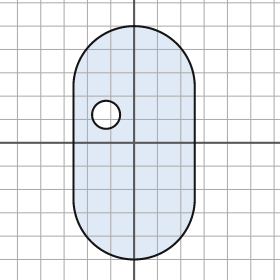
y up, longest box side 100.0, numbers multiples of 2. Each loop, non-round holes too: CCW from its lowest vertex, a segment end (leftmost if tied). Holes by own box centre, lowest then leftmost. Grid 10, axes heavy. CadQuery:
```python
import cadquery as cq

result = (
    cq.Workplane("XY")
    .moveTo(-26.0, -24.0)
    .threePointArc((0.0, -50.0), (26.0, -24.0))
    .lineTo(26.0, 24.0)
    .threePointArc((0.0, 50.0), (-26.0, 24.0))
    .close()
    .moveTo(-12.0, 12.0)
    .circle(6.0)
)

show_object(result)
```